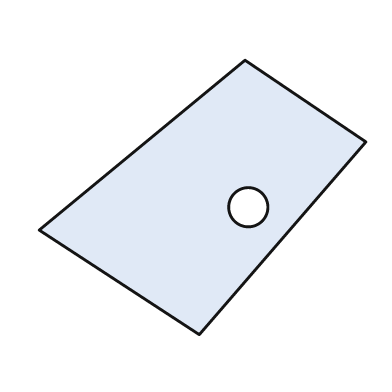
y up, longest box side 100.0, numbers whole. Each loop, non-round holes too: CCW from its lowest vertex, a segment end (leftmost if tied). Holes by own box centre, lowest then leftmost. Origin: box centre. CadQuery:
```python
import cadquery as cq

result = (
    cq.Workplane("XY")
    .moveTo(-1.0, -42.0)
    .lineTo(50.0, 17.0)
    .lineTo(13.0, 42.0)
    .lineTo(-50.0, -10.0)
    .close()
    .moveTo(14.0, -3.0)
    .circle(6.0)
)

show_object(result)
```